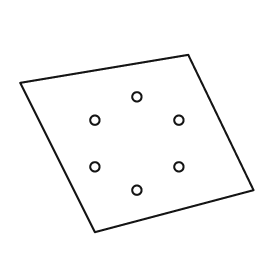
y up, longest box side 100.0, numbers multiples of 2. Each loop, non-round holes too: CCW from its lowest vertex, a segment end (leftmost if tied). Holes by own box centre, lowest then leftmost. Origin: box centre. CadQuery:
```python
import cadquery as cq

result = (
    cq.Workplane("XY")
    .moveTo(-18.0, -38.0)
    .lineTo(50.0, -20.0)
    .lineTo(22.0, 38.0)
    .lineTo(-50.0, 26.0)
    .close()
    .moveTo(0.0, -20.0)
    .circle(2.0)
    .moveTo(-18.0, -10.0)
    .circle(2.0)
    .moveTo(18.0, -10.0)
    .circle(2.0)
    .moveTo(-18.0, 10.0)
    .circle(2.0)
    .moveTo(18.0, 10.0)
    .circle(2.0)
    .moveTo(0.0, 20.0)
    .circle(2.0)
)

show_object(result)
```